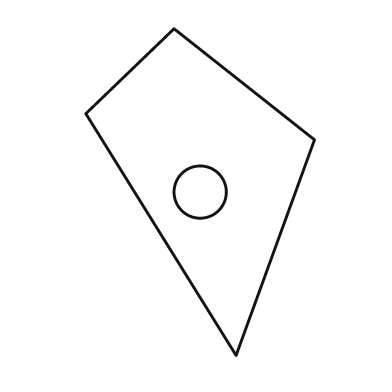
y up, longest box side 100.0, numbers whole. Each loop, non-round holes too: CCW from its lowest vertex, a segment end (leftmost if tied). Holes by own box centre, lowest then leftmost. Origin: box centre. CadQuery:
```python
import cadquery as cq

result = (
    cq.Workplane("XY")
    .moveTo(11.0, -50.0)
    .lineTo(35.0, 16.0)
    .lineTo(-8.0, 50.0)
    .lineTo(-35.0, 24.0)
    .close()
    .moveTo(0.0, 0.0)
    .circle(8.0)
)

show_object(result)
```